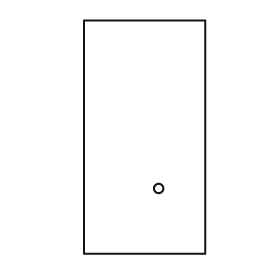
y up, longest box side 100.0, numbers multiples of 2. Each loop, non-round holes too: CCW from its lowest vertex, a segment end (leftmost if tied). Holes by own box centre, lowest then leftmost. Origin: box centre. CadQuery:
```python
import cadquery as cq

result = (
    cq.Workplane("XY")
    .moveTo(-26.0, -50.0)
    .lineTo(26.0, -50.0)
    .lineTo(26.0, 50.0)
    .lineTo(-26.0, 50.0)
    .close()
    .moveTo(6.0, -22.0)
    .circle(2.0)
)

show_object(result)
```